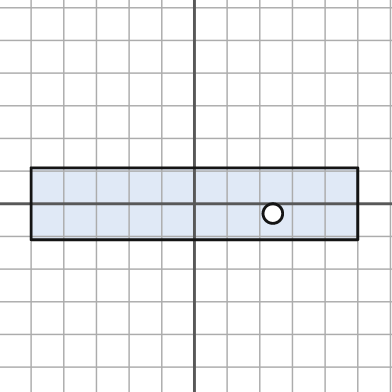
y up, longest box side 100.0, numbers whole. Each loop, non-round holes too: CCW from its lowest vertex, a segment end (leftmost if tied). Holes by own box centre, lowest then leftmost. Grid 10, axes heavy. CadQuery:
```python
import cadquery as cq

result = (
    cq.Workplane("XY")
    .moveTo(-50.0, -11.0)
    .lineTo(50.0, -11.0)
    .lineTo(50.0, 11.0)
    .lineTo(-50.0, 11.0)
    .close()
    .moveTo(24.0, -3.0)
    .circle(3.0)
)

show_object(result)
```